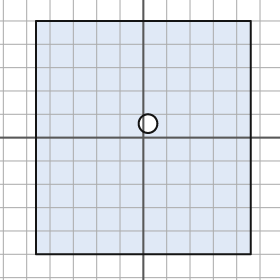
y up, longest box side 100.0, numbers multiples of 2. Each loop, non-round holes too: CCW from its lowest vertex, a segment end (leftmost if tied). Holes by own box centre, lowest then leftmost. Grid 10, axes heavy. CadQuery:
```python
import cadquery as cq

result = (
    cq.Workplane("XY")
    .moveTo(-46.0, -50.0)
    .lineTo(46.0, -50.0)
    .lineTo(46.0, 50.0)
    .lineTo(-46.0, 50.0)
    .close()
    .moveTo(2.0, 6.0)
    .circle(4.0)
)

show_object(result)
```